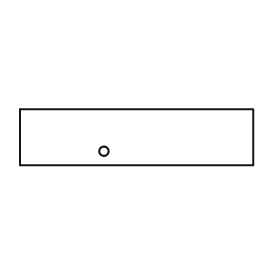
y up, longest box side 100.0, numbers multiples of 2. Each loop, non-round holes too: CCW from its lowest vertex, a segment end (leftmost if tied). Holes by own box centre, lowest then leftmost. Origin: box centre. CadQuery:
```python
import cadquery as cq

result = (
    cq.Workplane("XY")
    .moveTo(-50.0, -12.0)
    .lineTo(50.0, -12.0)
    .lineTo(50.0, 12.0)
    .lineTo(-50.0, 12.0)
    .close()
    .moveTo(-14.0, -6.0)
    .circle(2.0)
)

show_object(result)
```